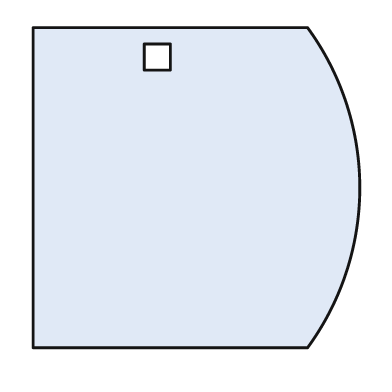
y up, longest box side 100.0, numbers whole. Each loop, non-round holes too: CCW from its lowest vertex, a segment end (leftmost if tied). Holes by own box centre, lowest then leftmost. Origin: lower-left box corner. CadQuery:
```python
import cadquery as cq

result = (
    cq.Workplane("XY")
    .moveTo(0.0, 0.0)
    .lineTo(84.0, 0.0)
    .threePointArc((100.0, 49.0), (84.0, 98.0))
    .lineTo(0.0, 98.0)
    .close()
    .moveTo(34.0, 85.0)
    .lineTo(42.0, 85.0)
    .lineTo(42.0, 93.0)
    .lineTo(34.0, 93.0)
    .close()
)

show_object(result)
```